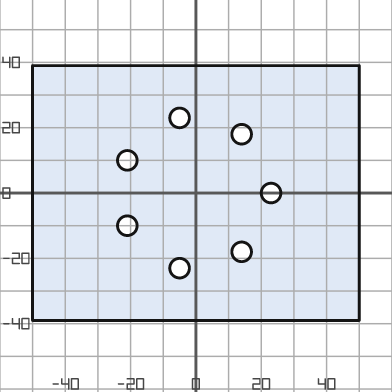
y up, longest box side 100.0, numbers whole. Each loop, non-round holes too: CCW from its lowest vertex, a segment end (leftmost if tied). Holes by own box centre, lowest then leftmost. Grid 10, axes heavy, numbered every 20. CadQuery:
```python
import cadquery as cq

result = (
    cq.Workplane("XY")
    .moveTo(-50.0, -39.0)
    .lineTo(50.0, -39.0)
    .lineTo(50.0, 39.0)
    .lineTo(-50.0, 39.0)
    .close()
    .moveTo(-5.0, -23.0)
    .circle(3.0)
    .moveTo(14.0, -18.0)
    .circle(3.0)
    .moveTo(-21.0, -10.0)
    .circle(3.0)
    .moveTo(23.0, 0.0)
    .circle(3.0)
    .moveTo(-21.0, 10.0)
    .circle(3.0)
    .moveTo(14.0, 18.0)
    .circle(3.0)
    .moveTo(-5.0, 23.0)
    .circle(3.0)
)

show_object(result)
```